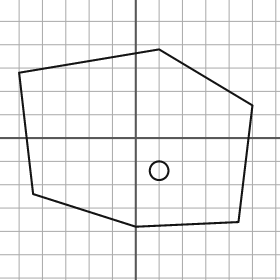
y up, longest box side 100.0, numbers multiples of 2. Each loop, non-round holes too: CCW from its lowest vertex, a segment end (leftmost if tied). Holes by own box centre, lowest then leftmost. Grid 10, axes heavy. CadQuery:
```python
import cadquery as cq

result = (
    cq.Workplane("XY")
    .moveTo(0.0, -38.0)
    .lineTo(44.0, -36.0)
    .lineTo(50.0, 14.0)
    .lineTo(10.0, 38.0)
    .lineTo(-50.0, 28.0)
    .lineTo(-44.0, -24.0)
    .close()
    .moveTo(10.0, -14.0)
    .circle(4.0)
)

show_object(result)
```